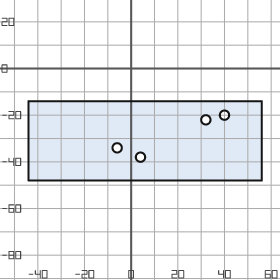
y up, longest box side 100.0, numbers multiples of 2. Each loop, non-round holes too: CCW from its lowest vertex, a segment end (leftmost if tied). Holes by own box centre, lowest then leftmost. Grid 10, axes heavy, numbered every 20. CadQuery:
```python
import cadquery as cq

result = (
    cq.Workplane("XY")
    .moveTo(-44.0, -48.0)
    .lineTo(56.0, -48.0)
    .lineTo(56.0, -14.0)
    .lineTo(-44.0, -14.0)
    .close()
    .moveTo(4.0, -38.0)
    .circle(2.0)
    .moveTo(-6.0, -34.0)
    .circle(2.0)
    .moveTo(32.0, -22.0)
    .circle(2.0)
    .moveTo(40.0, -20.0)
    .circle(2.0)
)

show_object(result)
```